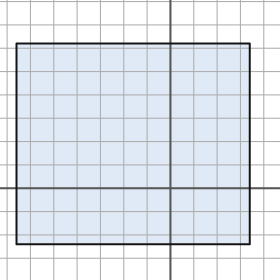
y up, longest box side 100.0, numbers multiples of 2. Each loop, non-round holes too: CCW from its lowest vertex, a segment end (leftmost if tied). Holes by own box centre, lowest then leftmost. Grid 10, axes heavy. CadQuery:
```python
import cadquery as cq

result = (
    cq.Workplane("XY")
    .moveTo(-66.0, -24.0)
    .lineTo(34.0, -24.0)
    .lineTo(34.0, 62.0)
    .lineTo(-66.0, 62.0)
    .close()
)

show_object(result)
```